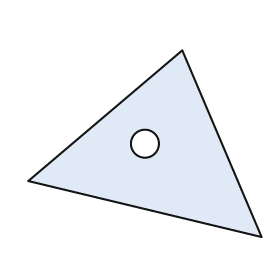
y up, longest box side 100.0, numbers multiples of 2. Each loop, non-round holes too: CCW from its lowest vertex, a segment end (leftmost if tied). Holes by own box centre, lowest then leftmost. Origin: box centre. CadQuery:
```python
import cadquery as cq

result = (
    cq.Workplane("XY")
    .moveTo(50.0, -40.0)
    .lineTo(16.0, 40.0)
    .lineTo(-50.0, -16.0)
    .close()
    .moveTo(0.0, 0.0)
    .circle(6.0)
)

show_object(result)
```